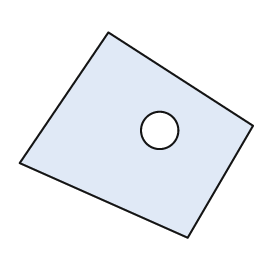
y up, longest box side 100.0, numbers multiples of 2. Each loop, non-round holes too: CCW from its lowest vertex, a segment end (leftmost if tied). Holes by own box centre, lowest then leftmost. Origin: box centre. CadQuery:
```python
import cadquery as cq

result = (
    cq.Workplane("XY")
    .moveTo(22.0, -44.0)
    .lineTo(50.0, 4.0)
    .lineTo(-12.0, 44.0)
    .lineTo(-50.0, -12.0)
    .close()
    .moveTo(10.0, 2.0)
    .circle(8.0)
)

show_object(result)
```